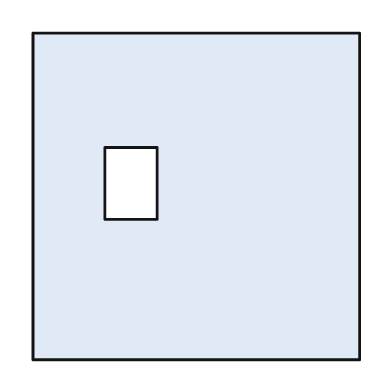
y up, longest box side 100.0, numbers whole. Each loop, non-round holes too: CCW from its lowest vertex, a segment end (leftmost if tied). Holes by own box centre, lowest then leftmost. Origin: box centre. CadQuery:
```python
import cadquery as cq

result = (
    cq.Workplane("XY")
    .moveTo(-50.0, -50.0)
    .lineTo(50.0, -50.0)
    .lineTo(50.0, 50.0)
    .lineTo(-50.0, 50.0)
    .close()
    .moveTo(-28.0, -7.0)
    .lineTo(-12.0, -7.0)
    .lineTo(-12.0, 15.0)
    .lineTo(-28.0, 15.0)
    .close()
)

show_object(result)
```